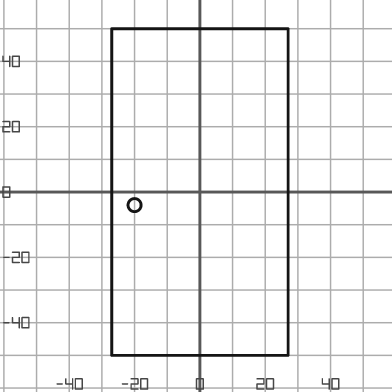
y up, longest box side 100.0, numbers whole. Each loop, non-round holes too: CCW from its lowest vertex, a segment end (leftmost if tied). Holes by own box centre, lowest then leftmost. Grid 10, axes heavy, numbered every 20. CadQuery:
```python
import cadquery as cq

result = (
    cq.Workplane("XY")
    .moveTo(-27.0, -50.0)
    .lineTo(27.0, -50.0)
    .lineTo(27.0, 50.0)
    .lineTo(-27.0, 50.0)
    .close()
    .moveTo(-20.0, -4.0)
    .circle(2.0)
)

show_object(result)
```